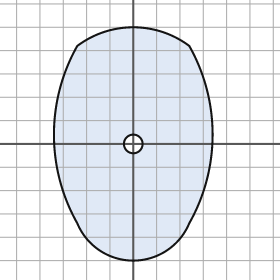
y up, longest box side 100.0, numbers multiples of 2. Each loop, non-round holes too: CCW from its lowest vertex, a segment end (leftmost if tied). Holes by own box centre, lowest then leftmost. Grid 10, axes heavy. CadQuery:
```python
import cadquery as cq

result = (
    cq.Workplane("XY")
    .moveTo(-24.0, -34.0)
    .threePointArc((0.0, -50.0), (24.0, -34.0))
    .threePointArc((34.0, 4.0), (24.0, 42.0))
    .threePointArc((0.0, 50.0), (-24.0, 42.0))
    .threePointArc((-34.0, 4.0), (-24.0, -34.0))
    .close()
    .moveTo(0.0, 0.0)
    .circle(4.0)
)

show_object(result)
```